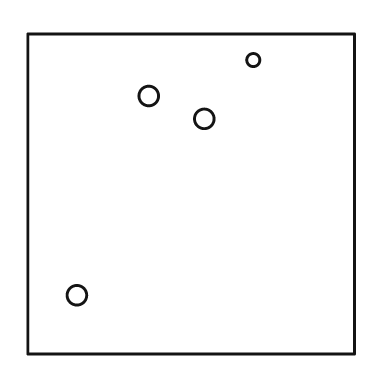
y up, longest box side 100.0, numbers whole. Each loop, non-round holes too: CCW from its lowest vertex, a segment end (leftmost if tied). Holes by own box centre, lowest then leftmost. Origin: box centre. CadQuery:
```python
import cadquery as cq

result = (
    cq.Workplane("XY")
    .moveTo(-50.0, -49.0)
    .lineTo(50.0, -49.0)
    .lineTo(50.0, 49.0)
    .lineTo(-50.0, 49.0)
    .close()
    .moveTo(-35.0, -31.0)
    .circle(3.0)
    .moveTo(4.0, 23.0)
    .circle(3.0)
    .moveTo(-13.0, 30.0)
    .circle(3.0)
    .moveTo(19.0, 41.0)
    .circle(2.0)
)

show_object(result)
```